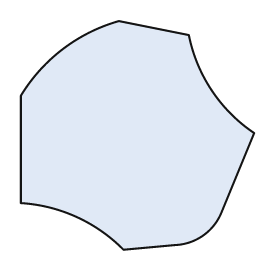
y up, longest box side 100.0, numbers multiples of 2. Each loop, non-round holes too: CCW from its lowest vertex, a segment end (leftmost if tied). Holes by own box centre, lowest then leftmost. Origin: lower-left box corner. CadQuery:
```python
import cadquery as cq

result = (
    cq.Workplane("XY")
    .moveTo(44.0, 0.0)
    .lineTo(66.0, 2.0)
    .threePointArc((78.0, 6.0), (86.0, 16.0))
    .lineTo(100.0, 50.0)
    .threePointArc((82.0, 68.0), (72.0, 92.0))
    .lineTo(42.0, 98.0)
    .threePointArc((18.0, 86.0), (0.0, 66.0))
    .lineTo(0.0, 20.0)
    .threePointArc((24.0, 14.0), (44.0, 0.0))
    .close()
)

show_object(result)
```